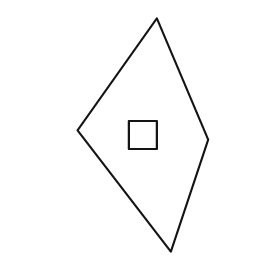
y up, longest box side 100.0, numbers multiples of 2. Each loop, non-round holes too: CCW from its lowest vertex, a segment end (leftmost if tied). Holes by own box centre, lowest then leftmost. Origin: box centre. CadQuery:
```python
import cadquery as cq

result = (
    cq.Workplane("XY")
    .moveTo(12.0, -50.0)
    .lineTo(28.0, -2.0)
    .lineTo(6.0, 50.0)
    .lineTo(-28.0, 2.0)
    .close()
    .moveTo(-6.0, -6.0)
    .lineTo(6.0, -6.0)
    .lineTo(6.0, 6.0)
    .lineTo(-6.0, 6.0)
    .close()
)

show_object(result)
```